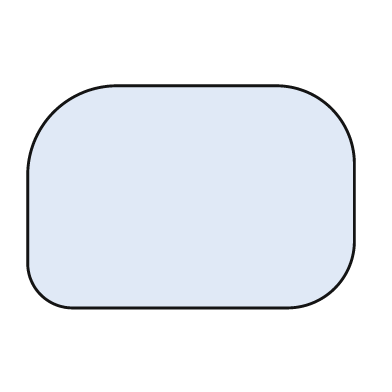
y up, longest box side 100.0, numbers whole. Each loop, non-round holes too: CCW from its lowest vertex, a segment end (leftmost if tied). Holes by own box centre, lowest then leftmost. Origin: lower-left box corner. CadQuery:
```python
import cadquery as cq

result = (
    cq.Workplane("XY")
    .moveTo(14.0, 0.0)
    .lineTo(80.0, 0.0)
    .threePointArc((94.0, 6.0), (100.0, 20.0))
    .lineTo(100.0, 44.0)
    .threePointArc((93.0, 61.0), (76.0, 68.0))
    .lineTo(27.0, 68.0)
    .threePointArc((8.0, 60.0), (0.0, 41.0))
    .lineTo(0.0, 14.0)
    .threePointArc((4.0, 4.0), (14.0, 0.0))
    .close()
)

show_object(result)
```